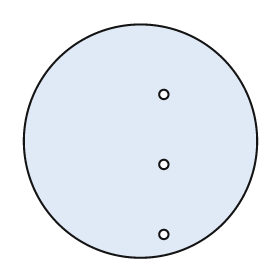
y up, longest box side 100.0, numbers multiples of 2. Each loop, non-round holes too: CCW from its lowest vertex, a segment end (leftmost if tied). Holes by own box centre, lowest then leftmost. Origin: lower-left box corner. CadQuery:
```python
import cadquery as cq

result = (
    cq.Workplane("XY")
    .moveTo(50.0, 50.0)
    .circle(50.0)
    .moveTo(60.0, 10.0)
    .circle(2.0)
    .moveTo(60.0, 40.0)
    .circle(2.0)
    .moveTo(60.0, 70.0)
    .circle(2.0)
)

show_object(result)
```